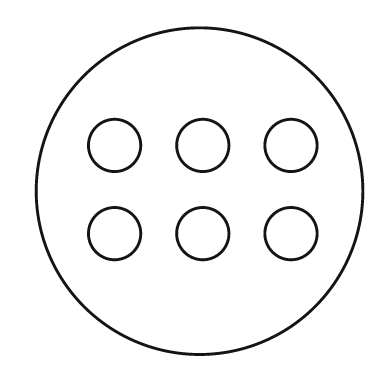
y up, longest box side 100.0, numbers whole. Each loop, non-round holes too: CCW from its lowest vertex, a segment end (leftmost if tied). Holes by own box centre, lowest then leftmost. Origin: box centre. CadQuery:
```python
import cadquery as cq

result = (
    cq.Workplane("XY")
    .moveTo(0.0, 0.0)
    .circle(50.0)
    .moveTo(-26.0, -13.0)
    .circle(8.0)
    .moveTo(1.0, -13.0)
    .circle(8.0)
    .moveTo(28.0, -13.0)
    .circle(8.0)
    .moveTo(-26.0, 14.0)
    .circle(8.0)
    .moveTo(1.0, 14.0)
    .circle(8.0)
    .moveTo(28.0, 14.0)
    .circle(8.0)
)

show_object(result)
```